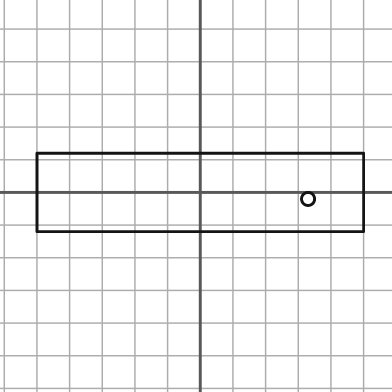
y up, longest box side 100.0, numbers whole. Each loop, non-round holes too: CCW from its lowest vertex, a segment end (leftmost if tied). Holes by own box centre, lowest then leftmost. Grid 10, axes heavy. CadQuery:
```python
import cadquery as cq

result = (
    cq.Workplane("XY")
    .moveTo(-50.0, -12.0)
    .lineTo(50.0, -12.0)
    .lineTo(50.0, 12.0)
    .lineTo(-50.0, 12.0)
    .close()
    .moveTo(33.0, -2.0)
    .circle(2.0)
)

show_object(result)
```